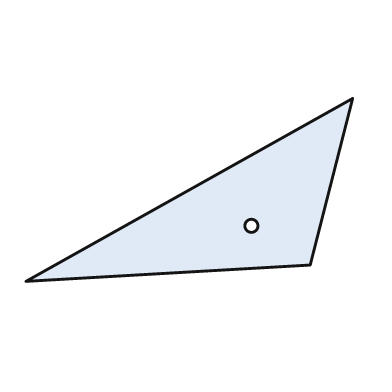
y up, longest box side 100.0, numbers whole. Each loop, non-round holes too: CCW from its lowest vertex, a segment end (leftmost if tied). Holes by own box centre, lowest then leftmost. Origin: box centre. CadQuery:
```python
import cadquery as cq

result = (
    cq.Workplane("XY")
    .moveTo(-50.0, -28.0)
    .lineTo(37.0, -23.0)
    .lineTo(50.0, 28.0)
    .close()
    .moveTo(19.0, -11.0)
    .circle(2.0)
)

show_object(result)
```